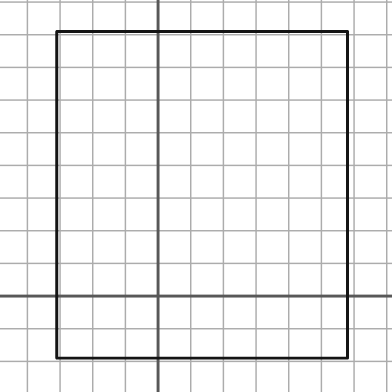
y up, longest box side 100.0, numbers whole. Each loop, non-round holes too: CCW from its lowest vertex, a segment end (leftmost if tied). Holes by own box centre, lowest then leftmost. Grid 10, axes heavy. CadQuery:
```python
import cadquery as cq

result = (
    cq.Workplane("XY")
    .moveTo(-31.0, -19.0)
    .lineTo(58.0, -19.0)
    .lineTo(58.0, 81.0)
    .lineTo(-31.0, 81.0)
    .close()
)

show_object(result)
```